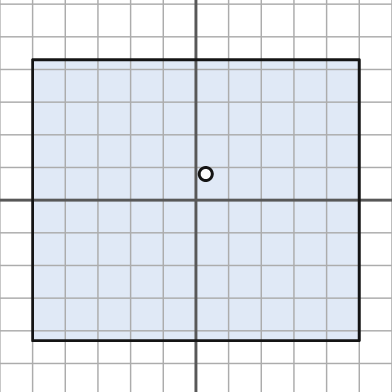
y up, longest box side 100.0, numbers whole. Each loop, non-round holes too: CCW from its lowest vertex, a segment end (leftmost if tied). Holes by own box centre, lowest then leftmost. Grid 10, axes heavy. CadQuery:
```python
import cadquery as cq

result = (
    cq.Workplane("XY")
    .moveTo(-50.0, -43.0)
    .lineTo(50.0, -43.0)
    .lineTo(50.0, 43.0)
    .lineTo(-50.0, 43.0)
    .close()
    .moveTo(3.0, 8.0)
    .circle(2.0)
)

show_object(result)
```